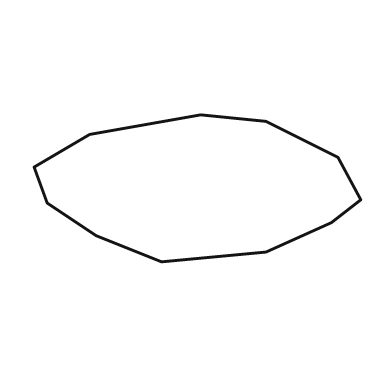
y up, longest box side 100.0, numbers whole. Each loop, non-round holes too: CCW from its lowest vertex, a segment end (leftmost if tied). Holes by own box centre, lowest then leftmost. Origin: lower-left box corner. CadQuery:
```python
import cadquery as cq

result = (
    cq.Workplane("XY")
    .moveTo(39.0, 0.0)
    .lineTo(71.0, 3.0)
    .lineTo(91.0, 12.0)
    .lineTo(100.0, 19.0)
    .lineTo(93.0, 32.0)
    .lineTo(71.0, 43.0)
    .lineTo(51.0, 45.0)
    .lineTo(17.0, 39.0)
    .lineTo(0.0, 29.0)
    .lineTo(4.0, 18.0)
    .lineTo(19.0, 8.0)
    .close()
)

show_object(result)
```